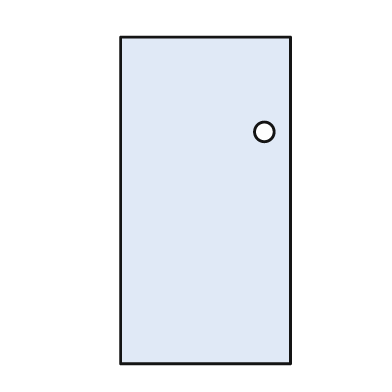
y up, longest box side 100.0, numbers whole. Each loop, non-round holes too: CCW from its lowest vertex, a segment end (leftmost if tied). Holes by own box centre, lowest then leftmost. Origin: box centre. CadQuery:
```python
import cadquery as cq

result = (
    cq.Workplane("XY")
    .moveTo(-26.0, -50.0)
    .lineTo(26.0, -50.0)
    .lineTo(26.0, 50.0)
    .lineTo(-26.0, 50.0)
    .close()
    .moveTo(18.0, 21.0)
    .circle(3.0)
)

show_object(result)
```